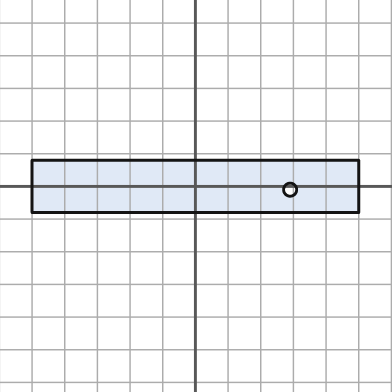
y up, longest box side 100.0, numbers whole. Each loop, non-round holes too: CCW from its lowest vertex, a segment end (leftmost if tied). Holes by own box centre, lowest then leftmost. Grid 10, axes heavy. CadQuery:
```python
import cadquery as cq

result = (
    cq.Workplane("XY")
    .moveTo(-50.0, -8.0)
    .lineTo(50.0, -8.0)
    .lineTo(50.0, 8.0)
    .lineTo(-50.0, 8.0)
    .close()
    .moveTo(29.0, -1.0)
    .circle(2.0)
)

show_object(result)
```